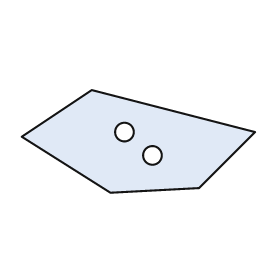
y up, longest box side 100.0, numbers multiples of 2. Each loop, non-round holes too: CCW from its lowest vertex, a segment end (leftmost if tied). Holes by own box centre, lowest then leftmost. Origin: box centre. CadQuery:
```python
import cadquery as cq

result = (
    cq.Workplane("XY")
    .moveTo(-12.0, -22.0)
    .lineTo(26.0, -20.0)
    .lineTo(50.0, 4.0)
    .lineTo(-20.0, 22.0)
    .lineTo(-50.0, 2.0)
    .close()
    .moveTo(6.0, -6.0)
    .circle(4.0)
    .moveTo(-6.0, 4.0)
    .circle(4.0)
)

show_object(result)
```